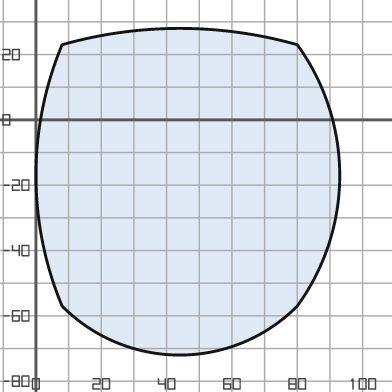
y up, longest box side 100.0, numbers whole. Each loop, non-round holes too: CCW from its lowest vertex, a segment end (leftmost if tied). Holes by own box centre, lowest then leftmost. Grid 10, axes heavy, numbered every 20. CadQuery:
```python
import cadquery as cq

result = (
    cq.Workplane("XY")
    .moveTo(8.0, -57.0)
    .threePointArc((44.0, -72.0), (80.0, -57.0))
    .threePointArc((93.0, -17.0), (80.0, 23.0))
    .threePointArc((44.0, 28.0), (8.0, 23.0))
    .threePointArc((0.0, -17.0), (8.0, -57.0))
    .close()
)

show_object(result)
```